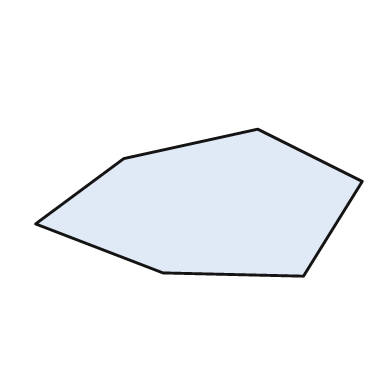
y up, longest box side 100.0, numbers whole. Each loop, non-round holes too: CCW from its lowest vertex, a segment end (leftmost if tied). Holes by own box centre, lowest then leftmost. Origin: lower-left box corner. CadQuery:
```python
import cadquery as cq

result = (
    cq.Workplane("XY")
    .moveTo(82.0, 0.0)
    .lineTo(100.0, 29.0)
    .lineTo(68.0, 45.0)
    .lineTo(27.0, 36.0)
    .lineTo(0.0, 16.0)
    .lineTo(39.0, 1.0)
    .close()
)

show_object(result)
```